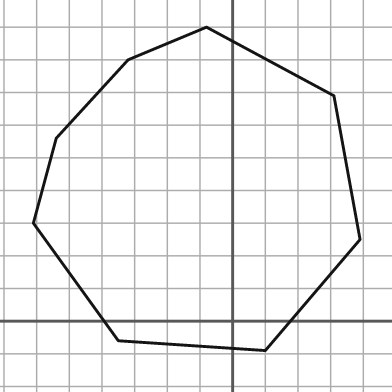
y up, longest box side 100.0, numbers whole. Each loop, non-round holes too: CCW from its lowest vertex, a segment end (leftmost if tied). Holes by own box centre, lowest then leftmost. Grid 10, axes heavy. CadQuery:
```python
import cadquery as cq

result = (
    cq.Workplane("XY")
    .moveTo(10.0, -9.0)
    .lineTo(39.0, 25.0)
    .lineTo(31.0, 69.0)
    .lineTo(-8.0, 90.0)
    .lineTo(-32.0, 80.0)
    .lineTo(-54.0, 56.0)
    .lineTo(-61.0, 30.0)
    .lineTo(-35.0, -6.0)
    .close()
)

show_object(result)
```